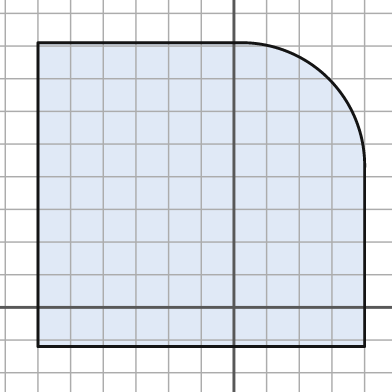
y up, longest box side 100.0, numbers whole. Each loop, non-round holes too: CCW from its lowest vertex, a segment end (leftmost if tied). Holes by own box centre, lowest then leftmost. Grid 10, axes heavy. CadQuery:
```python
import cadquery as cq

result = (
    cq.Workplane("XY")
    .moveTo(-60.0, -12.0)
    .lineTo(40.0, -12.0)
    .lineTo(40.0, 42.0)
    .threePointArc((29.0, 70.0), (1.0, 81.0))
    .lineTo(-60.0, 81.0)
    .close()
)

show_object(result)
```